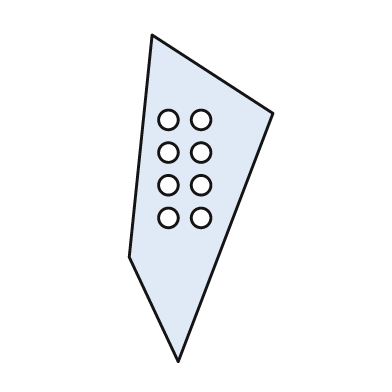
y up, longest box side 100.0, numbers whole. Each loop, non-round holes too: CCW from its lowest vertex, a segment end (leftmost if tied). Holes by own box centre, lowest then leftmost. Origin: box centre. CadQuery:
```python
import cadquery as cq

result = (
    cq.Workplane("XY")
    .moveTo(-7.0, -50.0)
    .lineTo(22.0, 26.0)
    .lineTo(-15.0, 50.0)
    .lineTo(-22.0, -18.0)
    .close()
    .moveTo(-10.0, -6.0)
    .circle(3.0)
    .moveTo(0.0, -6.0)
    .circle(3.0)
    .moveTo(-10.0, 4.0)
    .circle(3.0)
    .moveTo(0.0, 4.0)
    .circle(3.0)
    .moveTo(-10.0, 14.0)
    .circle(3.0)
    .moveTo(0.0, 14.0)
    .circle(3.0)
    .moveTo(-10.0, 24.0)
    .circle(3.0)
    .moveTo(0.0, 24.0)
    .circle(3.0)
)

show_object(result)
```